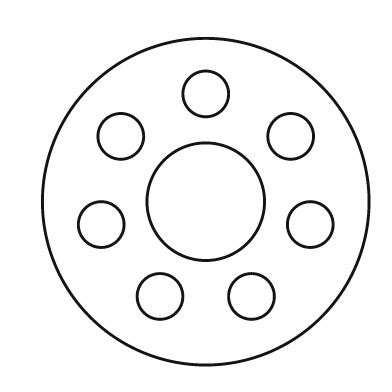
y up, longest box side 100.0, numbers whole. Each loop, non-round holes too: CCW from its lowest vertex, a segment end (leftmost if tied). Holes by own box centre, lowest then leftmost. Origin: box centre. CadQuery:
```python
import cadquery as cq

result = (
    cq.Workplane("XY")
    .moveTo(0.0, 0.0)
    .circle(50.0)
    .moveTo(-14.0, -29.0)
    .circle(7.0)
    .moveTo(14.0, -29.0)
    .circle(7.0)
    .moveTo(-32.0, -7.0)
    .circle(7.0)
    .moveTo(32.0, -7.0)
    .circle(7.0)
    .moveTo(0.0, 0.0)
    .circle(18.0)
    .moveTo(-26.0, 20.0)
    .circle(7.0)
    .moveTo(26.0, 20.0)
    .circle(7.0)
    .moveTo(0.0, 33.0)
    .circle(7.0)
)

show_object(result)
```